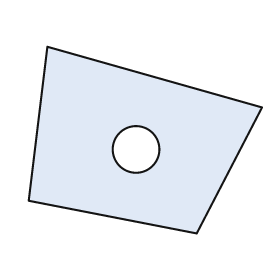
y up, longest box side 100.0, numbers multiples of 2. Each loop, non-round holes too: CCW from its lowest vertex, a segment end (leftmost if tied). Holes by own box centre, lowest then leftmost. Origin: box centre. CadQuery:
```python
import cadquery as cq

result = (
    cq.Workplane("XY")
    .moveTo(22.0, -40.0)
    .lineTo(50.0, 14.0)
    .lineTo(-42.0, 40.0)
    .lineTo(-50.0, -26.0)
    .close()
    .moveTo(-4.0, -4.0)
    .circle(10.0)
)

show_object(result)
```